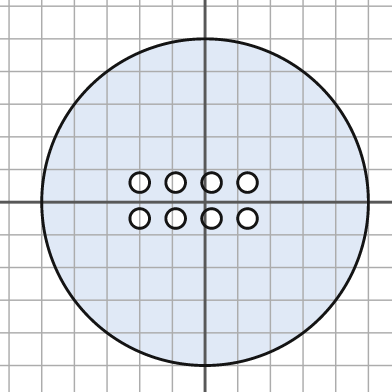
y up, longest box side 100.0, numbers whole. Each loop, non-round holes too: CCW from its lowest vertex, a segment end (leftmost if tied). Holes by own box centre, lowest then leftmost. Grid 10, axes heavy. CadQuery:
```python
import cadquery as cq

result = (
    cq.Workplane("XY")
    .moveTo(0.0, 0.0)
    .circle(50.0)
    .moveTo(-20.0, -5.0)
    .circle(3.0)
    .moveTo(-9.0, -5.0)
    .circle(3.0)
    .moveTo(2.0, -5.0)
    .circle(3.0)
    .moveTo(13.0, -5.0)
    .circle(3.0)
    .moveTo(-20.0, 6.0)
    .circle(3.0)
    .moveTo(-9.0, 6.0)
    .circle(3.0)
    .moveTo(2.0, 6.0)
    .circle(3.0)
    .moveTo(13.0, 6.0)
    .circle(3.0)
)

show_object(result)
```